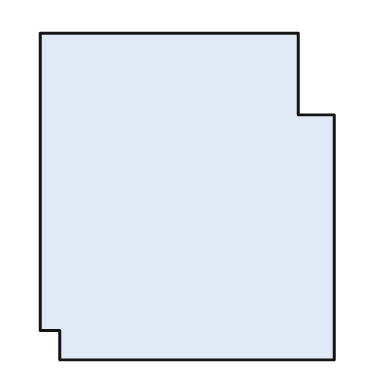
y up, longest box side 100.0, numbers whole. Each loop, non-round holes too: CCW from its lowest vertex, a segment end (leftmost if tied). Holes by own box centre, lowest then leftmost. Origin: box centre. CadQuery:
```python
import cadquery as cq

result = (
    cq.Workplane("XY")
    .moveTo(-39.0, -50.0)
    .lineTo(45.0, -50.0)
    .lineTo(45.0, 25.0)
    .lineTo(34.0, 25.0)
    .lineTo(34.0, 50.0)
    .lineTo(-45.0, 50.0)
    .lineTo(-45.0, -41.0)
    .lineTo(-39.0, -41.0)
    .close()
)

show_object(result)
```